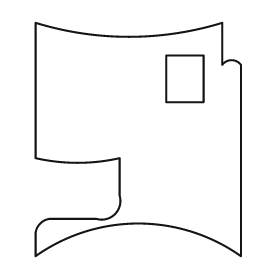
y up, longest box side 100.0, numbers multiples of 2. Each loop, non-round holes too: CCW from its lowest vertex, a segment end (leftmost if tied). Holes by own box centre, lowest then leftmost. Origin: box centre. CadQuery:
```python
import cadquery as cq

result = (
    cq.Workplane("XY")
    .moveTo(-44.0, -50.0)
    .threePointArc((0.0, -36.0), (44.0, -50.0))
    .lineTo(44.0, 32.0)
    .threePointArc((40.0, 34.0), (36.0, 32.0))
    .lineTo(36.0, 50.0)
    .threePointArc((-4.0, 44.0), (-44.0, 50.0))
    .lineTo(-44.0, -8.0)
    .threePointArc((-26.0, -10.0), (-8.0, -8.0))
    .lineTo(-8.0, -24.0)
    .threePointArc((-10.0, -32.0), (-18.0, -34.0))
    .lineTo(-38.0, -34.0)
    .threePointArc((-42.0, -36.0), (-44.0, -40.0))
    .close()
    .moveTo(12.0, 16.0)
    .lineTo(28.0, 16.0)
    .lineTo(28.0, 36.0)
    .lineTo(12.0, 36.0)
    .close()
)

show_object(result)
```